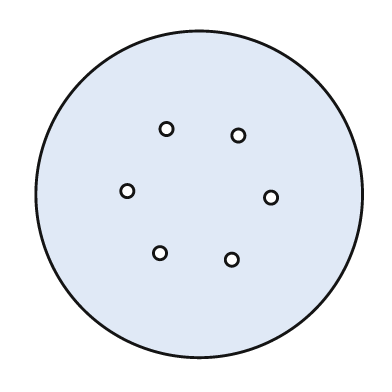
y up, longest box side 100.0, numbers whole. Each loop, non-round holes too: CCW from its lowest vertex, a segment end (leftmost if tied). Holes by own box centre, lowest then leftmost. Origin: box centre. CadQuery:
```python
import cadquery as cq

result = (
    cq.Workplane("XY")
    .moveTo(0.0, 0.0)
    .circle(50.0)
    .moveTo(10.0, -20.0)
    .circle(2.0)
    .moveTo(-12.0, -18.0)
    .circle(2.0)
    .moveTo(22.0, -1.0)
    .circle(2.0)
    .moveTo(-22.0, 1.0)
    .circle(2.0)
    .moveTo(12.0, 18.0)
    .circle(2.0)
    .moveTo(-10.0, 20.0)
    .circle(2.0)
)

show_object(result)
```